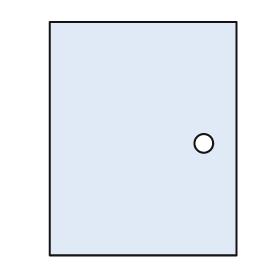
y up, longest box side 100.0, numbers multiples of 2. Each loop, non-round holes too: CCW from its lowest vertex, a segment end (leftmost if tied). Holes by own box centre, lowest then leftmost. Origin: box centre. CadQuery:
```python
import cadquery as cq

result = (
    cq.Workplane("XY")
    .moveTo(-40.0, -50.0)
    .lineTo(40.0, -50.0)
    .lineTo(40.0, 50.0)
    .lineTo(-40.0, 50.0)
    .close()
    .moveTo(26.0, -2.0)
    .circle(4.0)
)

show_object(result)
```